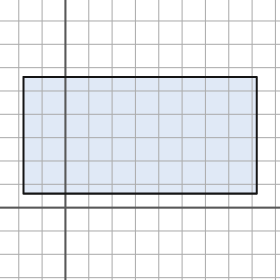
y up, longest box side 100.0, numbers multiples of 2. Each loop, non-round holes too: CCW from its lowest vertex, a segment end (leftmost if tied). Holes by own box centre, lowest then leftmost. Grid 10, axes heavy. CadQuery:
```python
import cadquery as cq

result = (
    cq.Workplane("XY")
    .moveTo(-18.0, 6.0)
    .lineTo(82.0, 6.0)
    .lineTo(82.0, 56.0)
    .lineTo(-18.0, 56.0)
    .close()
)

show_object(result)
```